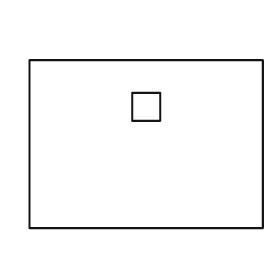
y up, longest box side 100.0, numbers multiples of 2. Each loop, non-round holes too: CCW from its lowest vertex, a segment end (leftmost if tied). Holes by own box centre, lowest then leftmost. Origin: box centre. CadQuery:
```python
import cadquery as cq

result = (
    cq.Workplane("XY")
    .moveTo(-50.0, -36.0)
    .lineTo(50.0, -36.0)
    .lineTo(50.0, 36.0)
    .lineTo(-50.0, 36.0)
    .close()
    .moveTo(-6.0, 10.0)
    .lineTo(6.0, 10.0)
    .lineTo(6.0, 22.0)
    .lineTo(-6.0, 22.0)
    .close()
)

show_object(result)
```